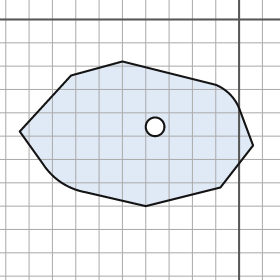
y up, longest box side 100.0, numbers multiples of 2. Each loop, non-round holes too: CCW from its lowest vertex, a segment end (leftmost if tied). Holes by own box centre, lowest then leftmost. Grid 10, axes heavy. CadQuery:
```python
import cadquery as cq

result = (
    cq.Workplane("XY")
    .moveTo(-40.0, -80.0)
    .lineTo(-8.0, -72.0)
    .lineTo(6.0, -54.0)
    .lineTo(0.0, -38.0)
    .threePointArc((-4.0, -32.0), (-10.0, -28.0))
    .lineTo(-50.0, -18.0)
    .lineTo(-72.0, -24.0)
    .lineTo(-94.0, -48.0)
    .lineTo(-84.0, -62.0)
    .threePointArc((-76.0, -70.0), (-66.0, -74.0))
    .close()
    .moveTo(-36.0, -46.0)
    .circle(4.0)
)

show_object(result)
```